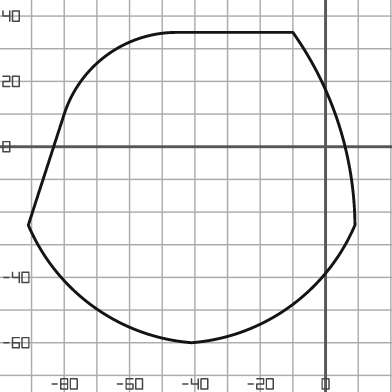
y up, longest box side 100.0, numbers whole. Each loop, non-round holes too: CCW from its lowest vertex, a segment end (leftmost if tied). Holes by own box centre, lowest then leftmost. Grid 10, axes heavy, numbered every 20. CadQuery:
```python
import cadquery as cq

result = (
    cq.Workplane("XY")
    .moveTo(-41.0, -60.0)
    .threePointArc((-11.0, -49.0), (9.0, -24.0))
    .threePointArc((4.0, 7.0), (-10.0, 35.0))
    .lineTo(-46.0, 35.0)
    .threePointArc((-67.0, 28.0), (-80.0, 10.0))
    .lineTo(-91.0, -24.0)
    .threePointArc((-71.0, -49.0), (-41.0, -60.0))
    .close()
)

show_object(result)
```